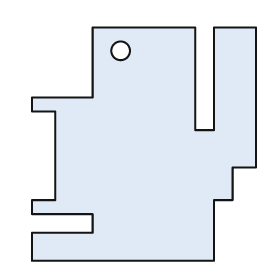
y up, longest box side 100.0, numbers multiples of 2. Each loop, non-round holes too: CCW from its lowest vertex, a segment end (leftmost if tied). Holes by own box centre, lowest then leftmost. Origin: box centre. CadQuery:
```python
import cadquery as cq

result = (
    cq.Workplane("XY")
    .moveTo(-48.0, -50.0)
    .lineTo(30.0, -50.0)
    .lineTo(30.0, -24.0)
    .lineTo(38.0, -24.0)
    .lineTo(38.0, -10.0)
    .lineTo(48.0, -10.0)
    .lineTo(48.0, 50.0)
    .lineTo(30.0, 50.0)
    .lineTo(30.0, 6.0)
    .lineTo(22.0, 6.0)
    .lineTo(22.0, 50.0)
    .lineTo(-22.0, 50.0)
    .lineTo(-22.0, 20.0)
    .lineTo(-48.0, 20.0)
    .lineTo(-48.0, 14.0)
    .lineTo(-38.0, 14.0)
    .lineTo(-38.0, -24.0)
    .lineTo(-48.0, -24.0)
    .lineTo(-48.0, -30.0)
    .lineTo(-22.0, -30.0)
    .lineTo(-22.0, -38.0)
    .lineTo(-48.0, -38.0)
    .close()
    .moveTo(-10.0, 40.0)
    .circle(4.0)
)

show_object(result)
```